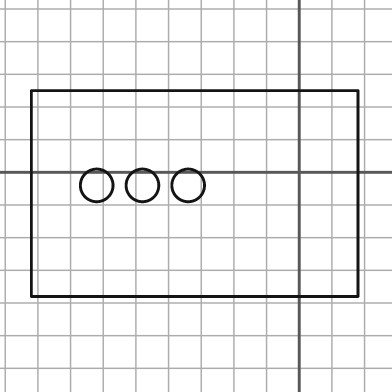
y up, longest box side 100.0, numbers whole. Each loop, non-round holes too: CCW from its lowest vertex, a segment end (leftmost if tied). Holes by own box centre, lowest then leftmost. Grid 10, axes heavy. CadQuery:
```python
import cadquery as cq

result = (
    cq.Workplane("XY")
    .moveTo(-82.0, -38.0)
    .lineTo(18.0, -38.0)
    .lineTo(18.0, 25.0)
    .lineTo(-82.0, 25.0)
    .close()
    .moveTo(-62.0, -4.0)
    .circle(5.0)
    .moveTo(-48.0, -4.0)
    .circle(5.0)
    .moveTo(-34.0, -4.0)
    .circle(5.0)
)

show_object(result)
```